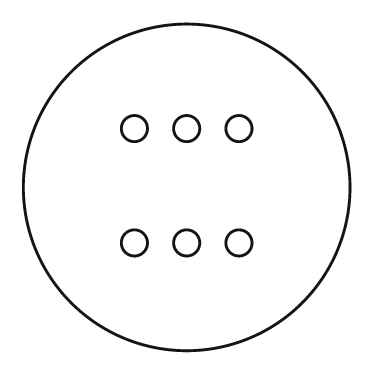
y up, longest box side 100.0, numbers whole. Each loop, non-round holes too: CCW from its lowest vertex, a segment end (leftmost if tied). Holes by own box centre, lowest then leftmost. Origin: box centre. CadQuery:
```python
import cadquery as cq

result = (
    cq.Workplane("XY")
    .moveTo(0.0, 0.0)
    .circle(50.0)
    .moveTo(-16.0, -17.0)
    .circle(4.0)
    .moveTo(0.0, -17.0)
    .circle(4.0)
    .moveTo(16.0, -17.0)
    .circle(4.0)
    .moveTo(-16.0, 18.0)
    .circle(4.0)
    .moveTo(0.0, 18.0)
    .circle(4.0)
    .moveTo(16.0, 18.0)
    .circle(4.0)
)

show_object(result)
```